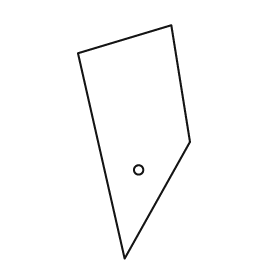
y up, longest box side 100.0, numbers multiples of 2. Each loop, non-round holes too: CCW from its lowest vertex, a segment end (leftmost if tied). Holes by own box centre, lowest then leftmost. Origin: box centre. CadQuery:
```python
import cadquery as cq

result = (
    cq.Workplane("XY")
    .moveTo(-4.0, -50.0)
    .lineTo(24.0, 0.0)
    .lineTo(16.0, 50.0)
    .lineTo(-24.0, 38.0)
    .close()
    .moveTo(2.0, -12.0)
    .circle(2.0)
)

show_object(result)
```